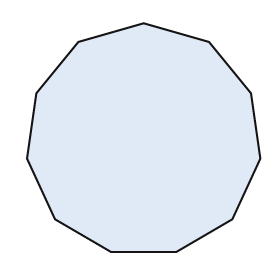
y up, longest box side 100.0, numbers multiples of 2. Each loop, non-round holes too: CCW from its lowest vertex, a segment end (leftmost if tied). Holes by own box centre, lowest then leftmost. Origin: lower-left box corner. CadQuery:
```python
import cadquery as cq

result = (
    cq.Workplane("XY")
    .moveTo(36.0, 0.0)
    .lineTo(64.0, 0.0)
    .lineTo(88.0, 14.0)
    .lineTo(100.0, 40.0)
    .lineTo(96.0, 68.0)
    .lineTo(78.0, 90.0)
    .lineTo(50.0, 98.0)
    .lineTo(22.0, 90.0)
    .lineTo(4.0, 68.0)
    .lineTo(0.0, 40.0)
    .lineTo(12.0, 14.0)
    .close()
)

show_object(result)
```